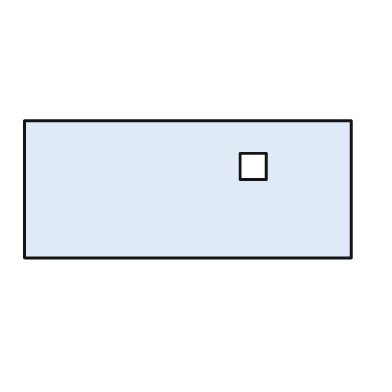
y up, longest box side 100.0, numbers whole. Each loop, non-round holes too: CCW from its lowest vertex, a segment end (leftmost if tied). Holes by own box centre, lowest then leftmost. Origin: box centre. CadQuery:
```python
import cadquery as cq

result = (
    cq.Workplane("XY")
    .moveTo(-50.0, -21.0)
    .lineTo(50.0, -21.0)
    .lineTo(50.0, 21.0)
    .lineTo(-50.0, 21.0)
    .close()
    .moveTo(16.0, 3.0)
    .lineTo(24.0, 3.0)
    .lineTo(24.0, 11.0)
    .lineTo(16.0, 11.0)
    .close()
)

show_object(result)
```